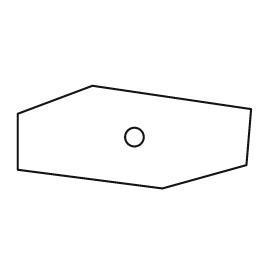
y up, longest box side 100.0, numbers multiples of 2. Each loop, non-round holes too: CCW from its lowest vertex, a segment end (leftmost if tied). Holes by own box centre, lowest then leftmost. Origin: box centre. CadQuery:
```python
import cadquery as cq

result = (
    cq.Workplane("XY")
    .moveTo(12.0, -22.0)
    .lineTo(48.0, -12.0)
    .lineTo(50.0, 12.0)
    .lineTo(-18.0, 22.0)
    .lineTo(-50.0, 10.0)
    .lineTo(-50.0, -14.0)
    .close()
    .moveTo(0.0, 0.0)
    .circle(4.0)
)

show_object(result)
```